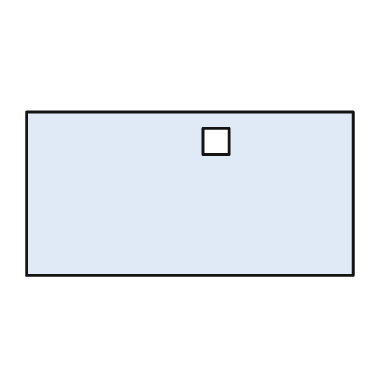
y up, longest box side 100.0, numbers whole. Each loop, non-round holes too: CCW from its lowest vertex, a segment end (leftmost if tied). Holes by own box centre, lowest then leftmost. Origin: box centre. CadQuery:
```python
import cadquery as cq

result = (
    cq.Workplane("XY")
    .moveTo(-50.0, -25.0)
    .lineTo(50.0, -25.0)
    .lineTo(50.0, 25.0)
    .lineTo(-50.0, 25.0)
    .close()
    .moveTo(4.0, 12.0)
    .lineTo(12.0, 12.0)
    .lineTo(12.0, 20.0)
    .lineTo(4.0, 20.0)
    .close()
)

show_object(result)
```